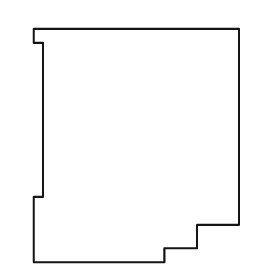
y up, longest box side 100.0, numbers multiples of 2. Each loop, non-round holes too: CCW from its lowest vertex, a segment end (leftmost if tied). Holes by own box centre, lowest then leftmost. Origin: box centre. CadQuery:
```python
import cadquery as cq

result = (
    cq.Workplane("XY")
    .moveTo(-44.0, -50.0)
    .lineTo(12.0, -50.0)
    .lineTo(12.0, -44.0)
    .lineTo(26.0, -44.0)
    .lineTo(26.0, -34.0)
    .lineTo(44.0, -34.0)
    .lineTo(44.0, 50.0)
    .lineTo(-44.0, 50.0)
    .lineTo(-44.0, 44.0)
    .lineTo(-40.0, 44.0)
    .lineTo(-40.0, -22.0)
    .lineTo(-44.0, -22.0)
    .close()
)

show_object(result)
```